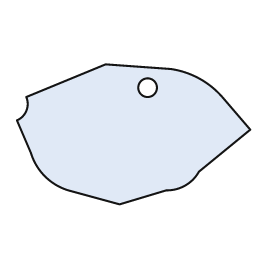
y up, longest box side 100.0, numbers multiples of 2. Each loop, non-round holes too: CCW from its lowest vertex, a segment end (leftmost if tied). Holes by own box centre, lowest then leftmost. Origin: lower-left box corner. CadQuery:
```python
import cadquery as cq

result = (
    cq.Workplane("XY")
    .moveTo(44.0, 0.0)
    .lineTo(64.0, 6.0)
    .threePointArc((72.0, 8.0), (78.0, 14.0))
    .lineTo(100.0, 32.0)
    .lineTo(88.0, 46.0)
    .threePointArc((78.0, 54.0), (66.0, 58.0))
    .lineTo(38.0, 60.0)
    .lineTo(4.0, 46.0)
    .threePointArc((4.0, 40.0), (0.0, 36.0))
    .lineTo(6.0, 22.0)
    .threePointArc((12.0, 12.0), (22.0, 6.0))
    .close()
    .moveTo(56.0, 50.0)
    .circle(4.0)
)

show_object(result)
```